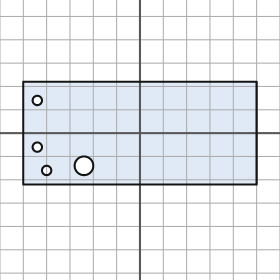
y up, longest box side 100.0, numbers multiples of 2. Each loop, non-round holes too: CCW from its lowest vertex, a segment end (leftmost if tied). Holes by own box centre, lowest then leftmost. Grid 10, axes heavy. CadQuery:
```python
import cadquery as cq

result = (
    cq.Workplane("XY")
    .moveTo(-50.0, -22.0)
    .lineTo(50.0, -22.0)
    .lineTo(50.0, 22.0)
    .lineTo(-50.0, 22.0)
    .close()
    .moveTo(-40.0, -16.0)
    .circle(2.0)
    .moveTo(-24.0, -14.0)
    .circle(4.0)
    .moveTo(-44.0, -6.0)
    .circle(2.0)
    .moveTo(-44.0, 14.0)
    .circle(2.0)
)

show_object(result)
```